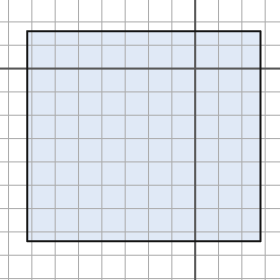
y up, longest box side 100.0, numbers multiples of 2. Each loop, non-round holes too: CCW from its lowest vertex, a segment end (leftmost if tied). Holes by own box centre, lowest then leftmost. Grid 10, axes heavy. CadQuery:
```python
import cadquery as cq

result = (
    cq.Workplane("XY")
    .moveTo(-72.0, -74.0)
    .lineTo(28.0, -74.0)
    .lineTo(28.0, 16.0)
    .lineTo(-72.0, 16.0)
    .close()
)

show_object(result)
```